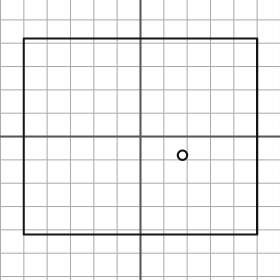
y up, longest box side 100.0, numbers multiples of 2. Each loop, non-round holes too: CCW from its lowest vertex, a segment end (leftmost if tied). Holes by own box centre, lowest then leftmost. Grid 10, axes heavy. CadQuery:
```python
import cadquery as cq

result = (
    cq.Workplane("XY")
    .moveTo(-50.0, -42.0)
    .lineTo(50.0, -42.0)
    .lineTo(50.0, 42.0)
    .lineTo(-50.0, 42.0)
    .close()
    .moveTo(18.0, -8.0)
    .circle(2.0)
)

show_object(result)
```